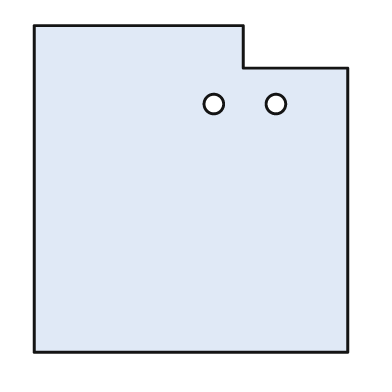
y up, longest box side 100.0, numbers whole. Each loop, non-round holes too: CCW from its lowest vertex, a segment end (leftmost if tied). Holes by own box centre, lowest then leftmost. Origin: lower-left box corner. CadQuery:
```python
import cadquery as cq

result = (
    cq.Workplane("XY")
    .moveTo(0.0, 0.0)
    .lineTo(96.0, 0.0)
    .lineTo(96.0, 87.0)
    .lineTo(64.0, 87.0)
    .lineTo(64.0, 100.0)
    .lineTo(0.0, 100.0)
    .close()
    .moveTo(55.0, 76.0)
    .circle(3.0)
    .moveTo(74.0, 76.0)
    .circle(3.0)
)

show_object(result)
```